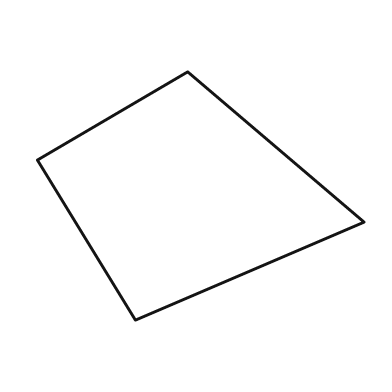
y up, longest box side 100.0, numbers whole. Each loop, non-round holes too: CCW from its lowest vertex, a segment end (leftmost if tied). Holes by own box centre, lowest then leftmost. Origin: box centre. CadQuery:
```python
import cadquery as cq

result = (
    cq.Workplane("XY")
    .moveTo(-20.0, -38.0)
    .lineTo(50.0, -8.0)
    .lineTo(-4.0, 38.0)
    .lineTo(-50.0, 11.0)
    .close()
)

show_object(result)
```